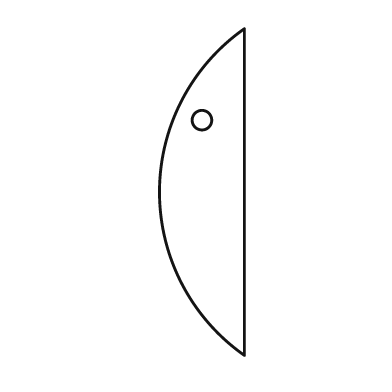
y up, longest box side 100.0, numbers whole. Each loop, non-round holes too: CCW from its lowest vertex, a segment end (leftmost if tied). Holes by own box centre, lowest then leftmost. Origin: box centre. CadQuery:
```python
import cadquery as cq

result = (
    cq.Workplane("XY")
    .moveTo(13.0, -50.0)
    .lineTo(13.0, 50.0)
    .threePointArc((-13.0, 0.0), (13.0, -50.0))
    .close()
    .moveTo(0.0, 22.0)
    .circle(3.0)
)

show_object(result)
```